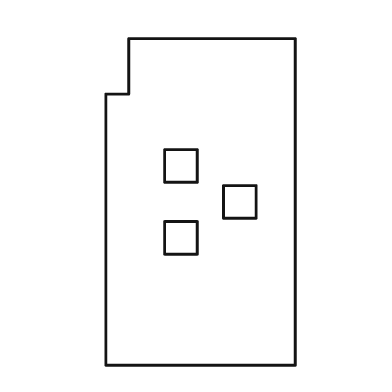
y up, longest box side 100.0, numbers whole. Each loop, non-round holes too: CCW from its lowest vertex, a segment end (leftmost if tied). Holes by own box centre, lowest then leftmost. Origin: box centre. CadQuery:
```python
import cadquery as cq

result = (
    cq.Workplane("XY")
    .moveTo(-29.0, -50.0)
    .lineTo(29.0, -50.0)
    .lineTo(29.0, 50.0)
    .lineTo(-22.0, 50.0)
    .lineTo(-22.0, 33.0)
    .lineTo(-29.0, 33.0)
    .close()
    .moveTo(-11.0, -16.0)
    .lineTo(-1.0, -16.0)
    .lineTo(-1.0, -6.0)
    .lineTo(-11.0, -6.0)
    .close()
    .moveTo(7.0, -5.0)
    .lineTo(17.0, -5.0)
    .lineTo(17.0, 5.0)
    .lineTo(7.0, 5.0)
    .close()
    .moveTo(-11.0, 6.0)
    .lineTo(-1.0, 6.0)
    .lineTo(-1.0, 16.0)
    .lineTo(-11.0, 16.0)
    .close()
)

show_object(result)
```